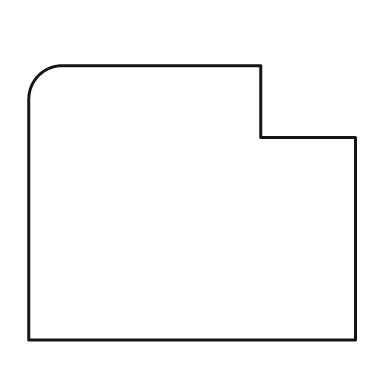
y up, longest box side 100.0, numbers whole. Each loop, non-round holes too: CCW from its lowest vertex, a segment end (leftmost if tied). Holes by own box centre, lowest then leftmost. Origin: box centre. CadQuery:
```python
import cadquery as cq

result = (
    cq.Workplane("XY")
    .moveTo(-50.0, -42.0)
    .lineTo(50.0, -42.0)
    .lineTo(50.0, 20.0)
    .lineTo(21.0, 20.0)
    .lineTo(21.0, 42.0)
    .lineTo(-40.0, 42.0)
    .threePointArc((-47.0, 39.0), (-50.0, 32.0))
    .close()
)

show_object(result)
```